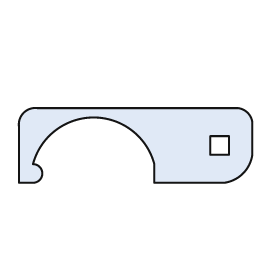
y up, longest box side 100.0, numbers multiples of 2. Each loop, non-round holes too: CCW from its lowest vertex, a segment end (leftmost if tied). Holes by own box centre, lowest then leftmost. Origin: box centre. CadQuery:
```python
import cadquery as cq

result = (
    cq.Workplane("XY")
    .moveTo(-50.0, -16.0)
    .lineTo(-44.0, -16.0)
    .threePointArc((-40.0, -12.0), (-44.0, -8.0))
    .threePointArc((-18.0, 12.0), (8.0, -8.0))
    .lineTo(8.0, -16.0)
    .lineTo(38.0, -16.0)
    .threePointArc((46.0, -12.0), (50.0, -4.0))
    .lineTo(50.0, 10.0)
    .threePointArc((48.0, 14.0), (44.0, 16.0))
    .lineTo(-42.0, 16.0)
    .threePointArc((-48.0, 14.0), (-50.0, 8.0))
    .close()
    .moveTo(32.0, -4.0)
    .lineTo(40.0, -4.0)
    .lineTo(40.0, 4.0)
    .lineTo(32.0, 4.0)
    .close()
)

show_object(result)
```